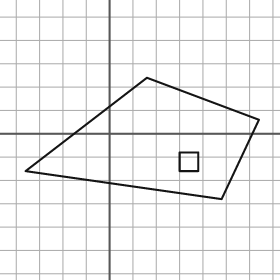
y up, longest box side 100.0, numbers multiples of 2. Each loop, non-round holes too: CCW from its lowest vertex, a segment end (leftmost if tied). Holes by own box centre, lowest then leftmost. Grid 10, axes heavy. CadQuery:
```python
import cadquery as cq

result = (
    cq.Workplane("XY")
    .moveTo(48.0, -28.0)
    .lineTo(64.0, 6.0)
    .lineTo(16.0, 24.0)
    .lineTo(-36.0, -16.0)
    .close()
    .moveTo(30.0, -16.0)
    .lineTo(38.0, -16.0)
    .lineTo(38.0, -8.0)
    .lineTo(30.0, -8.0)
    .close()
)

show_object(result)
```